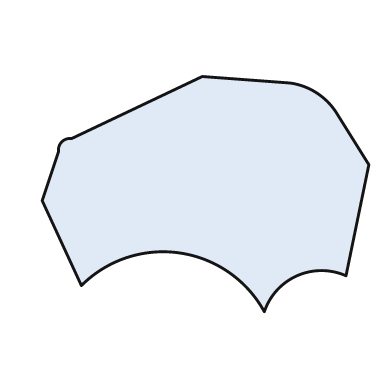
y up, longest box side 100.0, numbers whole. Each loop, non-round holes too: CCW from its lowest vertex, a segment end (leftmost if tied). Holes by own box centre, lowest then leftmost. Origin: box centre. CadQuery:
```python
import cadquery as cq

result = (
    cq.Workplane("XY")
    .moveTo(18.0, -36.0)
    .threePointArc((28.0, -25.0), (43.0, -25.0))
    .lineTo(50.0, 9.0)
    .lineTo(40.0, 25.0)
    .threePointArc((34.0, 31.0), (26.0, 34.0))
    .lineTo(-1.0, 36.0)
    .lineTo(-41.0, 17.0)
    .threePointArc((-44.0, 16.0), (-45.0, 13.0))
    .lineTo(-50.0, -2.0)
    .lineTo(-38.0, -28.0)
    .threePointArc((-8.0, -18.0), (18.0, -36.0))
    .close()
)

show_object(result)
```